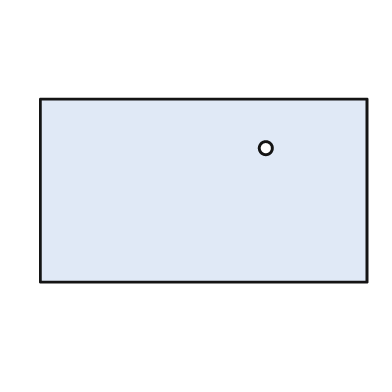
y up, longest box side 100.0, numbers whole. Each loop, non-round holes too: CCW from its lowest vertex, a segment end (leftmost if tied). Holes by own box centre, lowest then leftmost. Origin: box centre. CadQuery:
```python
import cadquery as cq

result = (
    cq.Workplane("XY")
    .moveTo(-50.0, -28.0)
    .lineTo(50.0, -28.0)
    .lineTo(50.0, 28.0)
    .lineTo(-50.0, 28.0)
    .close()
    .moveTo(19.0, 13.0)
    .circle(2.0)
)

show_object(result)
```